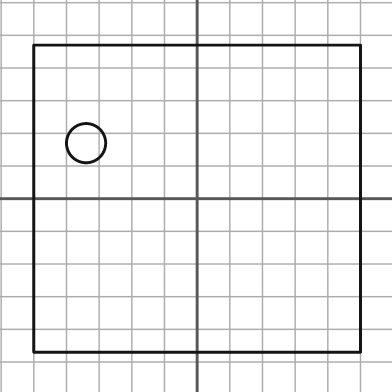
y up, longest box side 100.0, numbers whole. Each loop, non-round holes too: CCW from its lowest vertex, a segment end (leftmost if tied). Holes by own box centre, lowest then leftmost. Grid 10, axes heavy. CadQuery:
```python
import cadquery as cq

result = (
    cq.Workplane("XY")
    .moveTo(-50.0, -47.0)
    .lineTo(50.0, -47.0)
    .lineTo(50.0, 47.0)
    .lineTo(-50.0, 47.0)
    .close()
    .moveTo(-34.0, 17.0)
    .circle(6.0)
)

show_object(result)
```